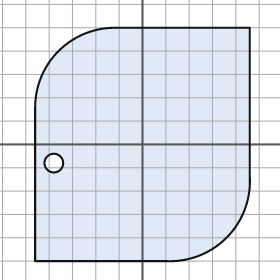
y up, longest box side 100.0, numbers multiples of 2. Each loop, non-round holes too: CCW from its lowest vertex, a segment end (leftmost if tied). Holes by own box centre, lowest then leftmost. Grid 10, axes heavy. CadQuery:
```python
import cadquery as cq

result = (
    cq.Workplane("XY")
    .moveTo(-46.0, -50.0)
    .lineTo(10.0, -50.0)
    .threePointArc((36.0, -40.0), (46.0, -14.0))
    .lineTo(46.0, 50.0)
    .lineTo(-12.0, 50.0)
    .threePointArc((-36.0, 40.0), (-46.0, 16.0))
    .close()
    .moveTo(-38.0, -8.0)
    .circle(4.0)
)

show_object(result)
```